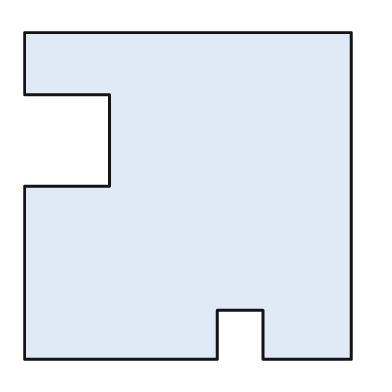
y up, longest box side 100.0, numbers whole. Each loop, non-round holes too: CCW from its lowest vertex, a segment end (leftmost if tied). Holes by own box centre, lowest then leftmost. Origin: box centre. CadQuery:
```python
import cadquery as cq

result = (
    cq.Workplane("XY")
    .moveTo(-50.0, -50.0)
    .lineTo(9.0, -50.0)
    .lineTo(9.0, -35.0)
    .lineTo(23.0, -35.0)
    .lineTo(23.0, -50.0)
    .lineTo(50.0, -50.0)
    .lineTo(50.0, 50.0)
    .lineTo(-50.0, 50.0)
    .lineTo(-50.0, 31.0)
    .lineTo(-24.0, 31.0)
    .lineTo(-24.0, 3.0)
    .lineTo(-50.0, 3.0)
    .close()
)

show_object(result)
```